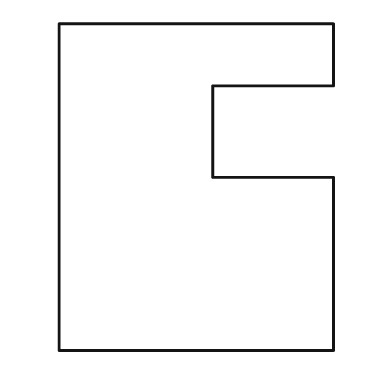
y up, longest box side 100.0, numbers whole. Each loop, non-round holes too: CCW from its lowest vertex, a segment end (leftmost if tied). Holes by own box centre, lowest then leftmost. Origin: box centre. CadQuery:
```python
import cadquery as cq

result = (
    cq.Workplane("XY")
    .moveTo(-42.0, -50.0)
    .lineTo(42.0, -50.0)
    .lineTo(42.0, 3.0)
    .lineTo(5.0, 3.0)
    .lineTo(5.0, 31.0)
    .lineTo(42.0, 31.0)
    .lineTo(42.0, 50.0)
    .lineTo(-42.0, 50.0)
    .close()
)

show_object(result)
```